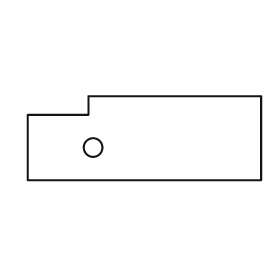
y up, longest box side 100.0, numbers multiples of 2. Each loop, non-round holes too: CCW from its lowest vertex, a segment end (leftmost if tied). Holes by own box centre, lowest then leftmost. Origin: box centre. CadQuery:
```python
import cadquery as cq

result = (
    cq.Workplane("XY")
    .moveTo(-50.0, -18.0)
    .lineTo(50.0, -18.0)
    .lineTo(50.0, 18.0)
    .lineTo(-24.0, 18.0)
    .lineTo(-24.0, 10.0)
    .lineTo(-50.0, 10.0)
    .close()
    .moveTo(-22.0, -4.0)
    .circle(4.0)
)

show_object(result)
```